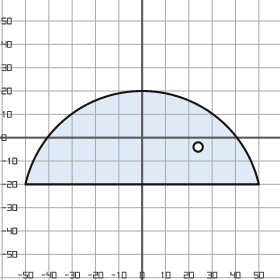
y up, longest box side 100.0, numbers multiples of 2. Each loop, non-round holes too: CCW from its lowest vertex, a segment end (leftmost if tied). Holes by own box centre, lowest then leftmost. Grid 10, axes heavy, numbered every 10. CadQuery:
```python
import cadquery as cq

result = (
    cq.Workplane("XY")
    .moveTo(-50.0, -20.0)
    .lineTo(50.0, -20.0)
    .threePointArc((0.0, 20.0), (-50.0, -20.0))
    .close()
    .moveTo(24.0, -4.0)
    .circle(2.0)
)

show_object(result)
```